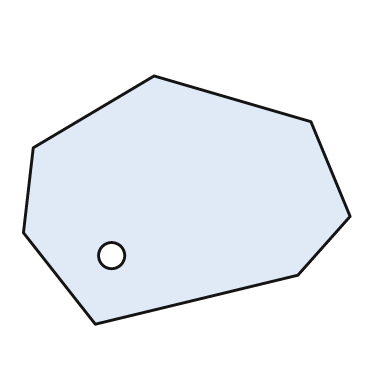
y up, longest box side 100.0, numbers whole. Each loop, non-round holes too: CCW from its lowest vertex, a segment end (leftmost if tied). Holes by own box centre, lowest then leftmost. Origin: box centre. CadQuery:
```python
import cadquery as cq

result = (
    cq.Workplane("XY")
    .moveTo(-28.0, -38.0)
    .lineTo(34.0, -23.0)
    .lineTo(50.0, -5.0)
    .lineTo(38.0, 24.0)
    .lineTo(-10.0, 38.0)
    .lineTo(-47.0, 16.0)
    .lineTo(-50.0, -10.0)
    .close()
    .moveTo(-23.0, -17.0)
    .circle(4.0)
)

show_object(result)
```